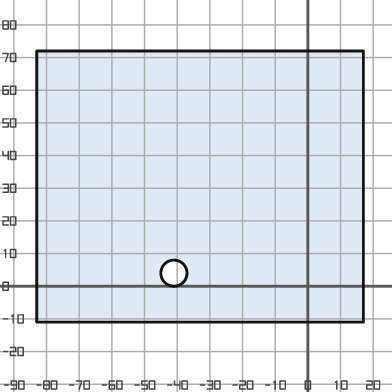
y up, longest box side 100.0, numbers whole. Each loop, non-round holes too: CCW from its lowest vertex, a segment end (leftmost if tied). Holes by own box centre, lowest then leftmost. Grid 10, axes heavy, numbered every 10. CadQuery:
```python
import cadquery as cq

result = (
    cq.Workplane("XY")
    .moveTo(-83.0, -11.0)
    .lineTo(17.0, -11.0)
    .lineTo(17.0, 72.0)
    .lineTo(-83.0, 72.0)
    .close()
    .moveTo(-41.0, 4.0)
    .circle(4.0)
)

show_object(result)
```